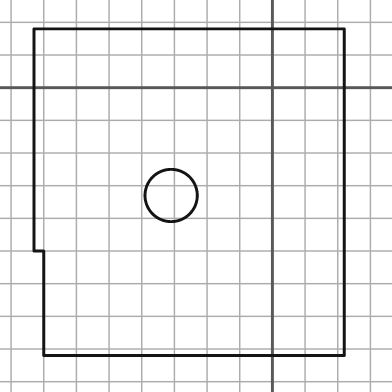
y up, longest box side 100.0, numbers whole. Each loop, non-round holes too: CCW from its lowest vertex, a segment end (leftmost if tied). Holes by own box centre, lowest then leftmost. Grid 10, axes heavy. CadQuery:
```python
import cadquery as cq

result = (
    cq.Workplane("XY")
    .moveTo(-70.0, -82.0)
    .lineTo(22.0, -82.0)
    .lineTo(22.0, 18.0)
    .lineTo(-73.0, 18.0)
    .lineTo(-73.0, -50.0)
    .lineTo(-70.0, -50.0)
    .close()
    .moveTo(-31.0, -33.0)
    .circle(8.0)
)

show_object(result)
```